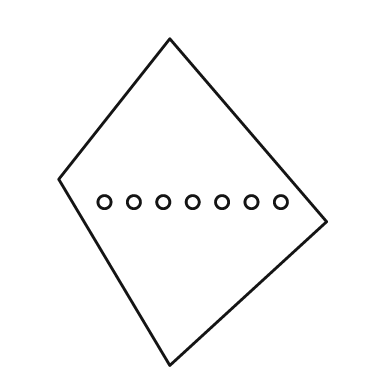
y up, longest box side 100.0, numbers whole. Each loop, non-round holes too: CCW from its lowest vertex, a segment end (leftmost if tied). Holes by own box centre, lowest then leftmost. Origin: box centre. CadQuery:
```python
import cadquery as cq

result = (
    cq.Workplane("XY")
    .moveTo(-7.0, -50.0)
    .lineTo(41.0, -6.0)
    .lineTo(-7.0, 50.0)
    .lineTo(-41.0, 7.0)
    .close()
    .moveTo(-27.0, 0.0)
    .circle(2.0)
    .moveTo(-18.0, 0.0)
    .circle(2.0)
    .moveTo(-9.0, 0.0)
    .circle(2.0)
    .moveTo(0.0, 0.0)
    .circle(2.0)
    .moveTo(9.0, 0.0)
    .circle(2.0)
    .moveTo(18.0, 0.0)
    .circle(2.0)
    .moveTo(27.0, 0.0)
    .circle(2.0)
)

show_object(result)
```